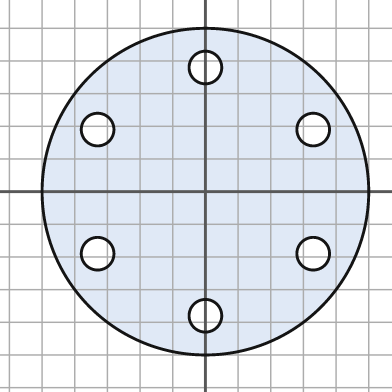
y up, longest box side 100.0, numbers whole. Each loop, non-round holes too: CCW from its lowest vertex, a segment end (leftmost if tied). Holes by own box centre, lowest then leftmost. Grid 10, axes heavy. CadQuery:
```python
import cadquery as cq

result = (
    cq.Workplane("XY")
    .moveTo(0.0, 0.0)
    .circle(50.0)
    .moveTo(0.0, -38.0)
    .circle(5.0)
    .moveTo(-33.0, -19.0)
    .circle(5.0)
    .moveTo(33.0, -19.0)
    .circle(5.0)
    .moveTo(-33.0, 19.0)
    .circle(5.0)
    .moveTo(33.0, 19.0)
    .circle(5.0)
    .moveTo(0.0, 38.0)
    .circle(5.0)
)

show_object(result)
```